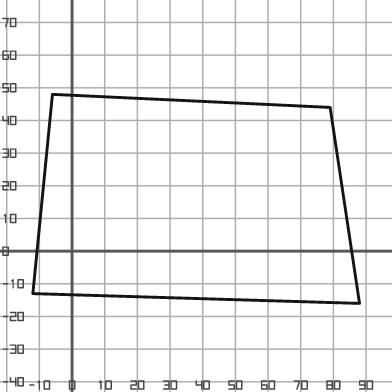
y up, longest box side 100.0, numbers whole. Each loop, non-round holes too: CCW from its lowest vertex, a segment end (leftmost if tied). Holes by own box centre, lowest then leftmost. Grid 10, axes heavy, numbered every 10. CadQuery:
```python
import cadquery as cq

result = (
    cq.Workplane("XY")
    .moveTo(88.0, -16.0)
    .lineTo(79.0, 44.0)
    .lineTo(-6.0, 48.0)
    .lineTo(-12.0, -13.0)
    .close()
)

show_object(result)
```